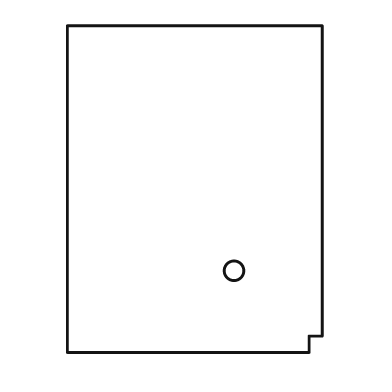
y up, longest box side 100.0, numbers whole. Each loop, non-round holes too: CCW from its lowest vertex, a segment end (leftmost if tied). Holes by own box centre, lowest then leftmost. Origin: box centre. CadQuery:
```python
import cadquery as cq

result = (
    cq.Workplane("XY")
    .moveTo(-39.0, -50.0)
    .lineTo(35.0, -50.0)
    .lineTo(35.0, -45.0)
    .lineTo(39.0, -45.0)
    .lineTo(39.0, 50.0)
    .lineTo(-39.0, 50.0)
    .close()
    .moveTo(12.0, -25.0)
    .circle(3.0)
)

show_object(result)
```